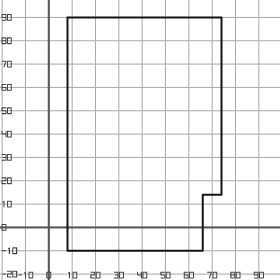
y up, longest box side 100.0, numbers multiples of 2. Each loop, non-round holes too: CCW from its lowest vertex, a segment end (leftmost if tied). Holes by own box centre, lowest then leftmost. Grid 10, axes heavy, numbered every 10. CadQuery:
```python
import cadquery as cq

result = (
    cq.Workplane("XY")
    .moveTo(8.0, -10.0)
    .lineTo(66.0, -10.0)
    .lineTo(66.0, 14.0)
    .lineTo(74.0, 14.0)
    .lineTo(74.0, 90.0)
    .lineTo(8.0, 90.0)
    .close()
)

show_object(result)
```